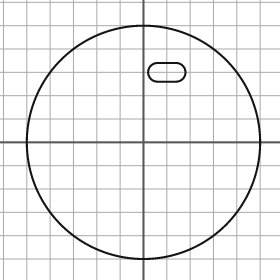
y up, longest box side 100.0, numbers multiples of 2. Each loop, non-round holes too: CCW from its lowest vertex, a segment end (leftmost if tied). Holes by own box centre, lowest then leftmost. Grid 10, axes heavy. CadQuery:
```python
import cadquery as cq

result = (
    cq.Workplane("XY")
    .moveTo(0.0, 0.0)
    .circle(50.0)
    .moveTo(6.0, 26.0)
    .lineTo(14.0, 26.0)
    .threePointArc((18.0, 30.0), (14.0, 34.0))
    .lineTo(6.0, 34.0)
    .threePointArc((2.0, 30.0), (6.0, 26.0))
    .close()
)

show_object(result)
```